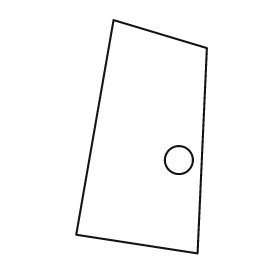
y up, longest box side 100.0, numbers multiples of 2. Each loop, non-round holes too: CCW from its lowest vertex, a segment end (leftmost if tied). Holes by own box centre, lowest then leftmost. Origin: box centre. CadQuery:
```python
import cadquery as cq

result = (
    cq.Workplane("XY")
    .moveTo(24.0, -50.0)
    .lineTo(28.0, 38.0)
    .lineTo(-12.0, 50.0)
    .lineTo(-28.0, -42.0)
    .close()
    .moveTo(16.0, -10.0)
    .circle(6.0)
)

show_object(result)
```